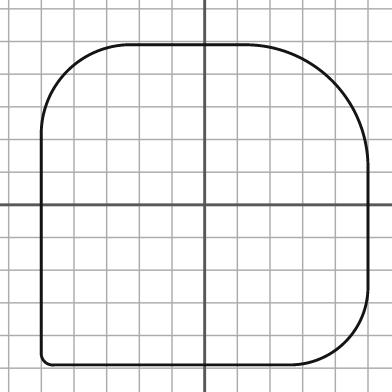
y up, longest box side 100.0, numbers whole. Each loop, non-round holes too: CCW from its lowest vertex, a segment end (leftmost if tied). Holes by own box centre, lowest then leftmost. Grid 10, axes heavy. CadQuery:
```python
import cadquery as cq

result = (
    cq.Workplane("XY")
    .moveTo(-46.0, -49.0)
    .lineTo(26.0, -49.0)
    .threePointArc((43.0, -42.0), (50.0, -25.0))
    .lineTo(50.0, 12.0)
    .threePointArc((39.0, 38.0), (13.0, 49.0))
    .lineTo(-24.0, 49.0)
    .threePointArc((-42.0, 41.0), (-50.0, 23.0))
    .lineTo(-50.0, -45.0)
    .threePointArc((-49.0, -48.0), (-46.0, -49.0))
    .close()
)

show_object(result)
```